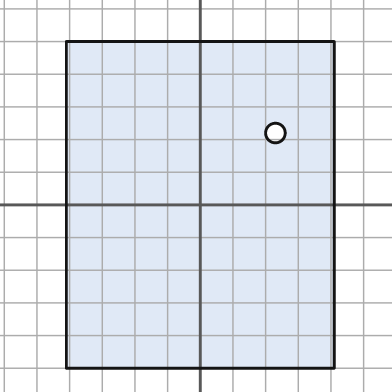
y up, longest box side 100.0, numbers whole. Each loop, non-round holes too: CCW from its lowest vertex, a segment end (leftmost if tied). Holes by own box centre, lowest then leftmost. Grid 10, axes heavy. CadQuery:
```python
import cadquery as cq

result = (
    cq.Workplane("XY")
    .moveTo(-41.0, -50.0)
    .lineTo(41.0, -50.0)
    .lineTo(41.0, 50.0)
    .lineTo(-41.0, 50.0)
    .close()
    .moveTo(23.0, 22.0)
    .circle(3.0)
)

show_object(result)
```